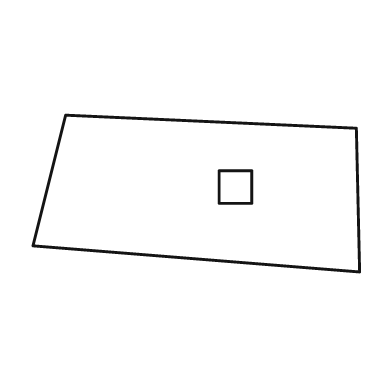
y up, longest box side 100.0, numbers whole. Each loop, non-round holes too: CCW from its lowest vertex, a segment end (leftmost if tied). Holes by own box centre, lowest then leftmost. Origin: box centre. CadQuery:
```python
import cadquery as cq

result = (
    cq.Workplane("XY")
    .moveTo(50.0, -24.0)
    .lineTo(49.0, 20.0)
    .lineTo(-40.0, 24.0)
    .lineTo(-50.0, -16.0)
    .close()
    .moveTo(7.0, -3.0)
    .lineTo(17.0, -3.0)
    .lineTo(17.0, 7.0)
    .lineTo(7.0, 7.0)
    .close()
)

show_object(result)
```